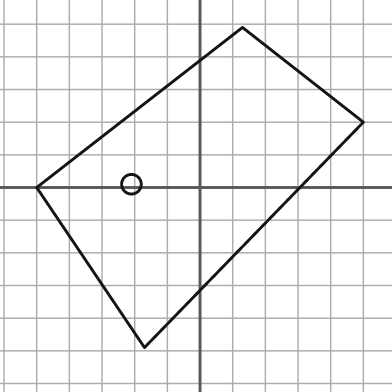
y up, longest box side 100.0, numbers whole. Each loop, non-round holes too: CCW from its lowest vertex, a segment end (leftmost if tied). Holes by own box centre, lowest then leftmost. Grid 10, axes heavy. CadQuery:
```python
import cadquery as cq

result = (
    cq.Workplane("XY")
    .moveTo(-17.0, -49.0)
    .lineTo(50.0, 20.0)
    .lineTo(13.0, 49.0)
    .lineTo(-50.0, 0.0)
    .close()
    .moveTo(-21.0, 1.0)
    .circle(3.0)
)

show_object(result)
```